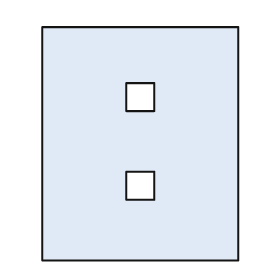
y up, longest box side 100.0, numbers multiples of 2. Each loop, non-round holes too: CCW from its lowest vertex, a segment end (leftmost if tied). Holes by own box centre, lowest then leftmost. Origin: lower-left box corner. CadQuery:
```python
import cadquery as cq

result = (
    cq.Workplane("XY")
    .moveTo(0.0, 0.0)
    .lineTo(84.0, 0.0)
    .lineTo(84.0, 100.0)
    .lineTo(0.0, 100.0)
    .close()
    .moveTo(36.0, 26.0)
    .lineTo(48.0, 26.0)
    .lineTo(48.0, 38.0)
    .lineTo(36.0, 38.0)
    .close()
    .moveTo(36.0, 64.0)
    .lineTo(48.0, 64.0)
    .lineTo(48.0, 76.0)
    .lineTo(36.0, 76.0)
    .close()
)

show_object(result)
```